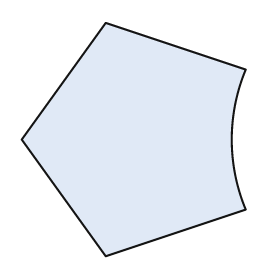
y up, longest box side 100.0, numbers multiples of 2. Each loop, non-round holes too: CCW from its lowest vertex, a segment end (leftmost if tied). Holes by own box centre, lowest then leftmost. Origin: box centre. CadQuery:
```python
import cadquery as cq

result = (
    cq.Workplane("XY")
    .moveTo(-12.0, -50.0)
    .lineTo(48.0, -30.0)
    .threePointArc((42.0, 0.0), (48.0, 30.0))
    .lineTo(-12.0, 50.0)
    .lineTo(-48.0, 0.0)
    .close()
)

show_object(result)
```